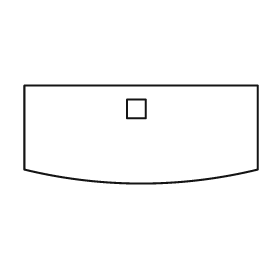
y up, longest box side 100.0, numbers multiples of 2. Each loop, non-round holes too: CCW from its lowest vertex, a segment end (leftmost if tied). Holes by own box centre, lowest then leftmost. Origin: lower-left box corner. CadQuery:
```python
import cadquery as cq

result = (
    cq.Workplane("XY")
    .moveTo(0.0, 6.0)
    .threePointArc((50.0, 0.0), (100.0, 6.0))
    .lineTo(100.0, 42.0)
    .lineTo(0.0, 42.0)
    .close()
    .moveTo(44.0, 28.0)
    .lineTo(52.0, 28.0)
    .lineTo(52.0, 36.0)
    .lineTo(44.0, 36.0)
    .close()
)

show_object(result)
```